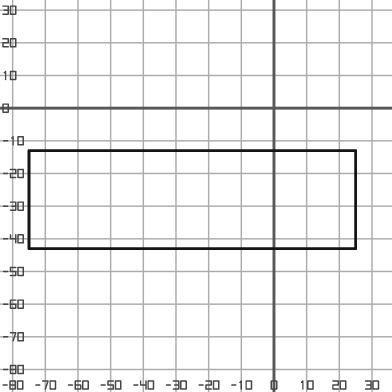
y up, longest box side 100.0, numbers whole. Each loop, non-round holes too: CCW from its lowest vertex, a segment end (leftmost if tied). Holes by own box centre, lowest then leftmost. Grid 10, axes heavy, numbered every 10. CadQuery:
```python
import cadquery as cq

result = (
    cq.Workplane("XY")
    .moveTo(-75.0, -43.0)
    .lineTo(25.0, -43.0)
    .lineTo(25.0, -13.0)
    .lineTo(-75.0, -13.0)
    .close()
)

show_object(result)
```